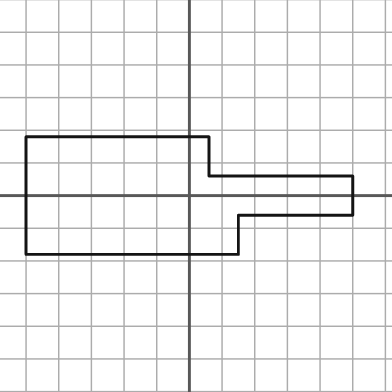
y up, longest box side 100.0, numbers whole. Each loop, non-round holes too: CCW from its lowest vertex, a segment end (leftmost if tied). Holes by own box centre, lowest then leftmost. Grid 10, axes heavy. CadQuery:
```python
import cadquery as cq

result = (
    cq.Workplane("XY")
    .moveTo(-50.0, -18.0)
    .lineTo(15.0, -18.0)
    .lineTo(15.0, -6.0)
    .lineTo(50.0, -6.0)
    .lineTo(50.0, 6.0)
    .lineTo(6.0, 6.0)
    .lineTo(6.0, 18.0)
    .lineTo(-50.0, 18.0)
    .close()
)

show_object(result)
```